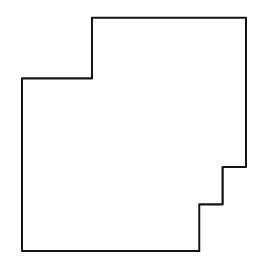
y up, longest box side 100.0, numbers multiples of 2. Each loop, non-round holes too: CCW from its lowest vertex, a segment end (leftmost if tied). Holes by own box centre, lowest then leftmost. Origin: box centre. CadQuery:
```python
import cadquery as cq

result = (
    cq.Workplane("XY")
    .moveTo(-48.0, -50.0)
    .lineTo(28.0, -50.0)
    .lineTo(28.0, -30.0)
    .lineTo(38.0, -30.0)
    .lineTo(38.0, -14.0)
    .lineTo(48.0, -14.0)
    .lineTo(48.0, 50.0)
    .lineTo(-18.0, 50.0)
    .lineTo(-18.0, 24.0)
    .lineTo(-48.0, 24.0)
    .close()
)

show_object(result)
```